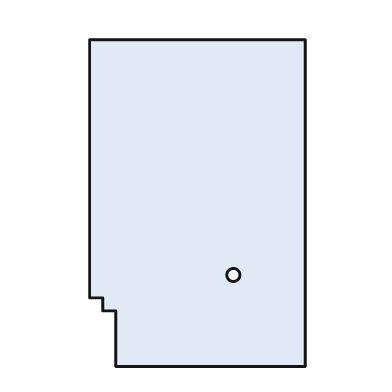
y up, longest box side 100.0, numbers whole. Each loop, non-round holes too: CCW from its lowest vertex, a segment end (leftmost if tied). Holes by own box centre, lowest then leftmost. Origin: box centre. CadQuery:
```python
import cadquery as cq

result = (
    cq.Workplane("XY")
    .moveTo(-25.0, -50.0)
    .lineTo(33.0, -50.0)
    .lineTo(33.0, 50.0)
    .lineTo(-33.0, 50.0)
    .lineTo(-33.0, -29.0)
    .lineTo(-29.0, -29.0)
    .lineTo(-29.0, -33.0)
    .lineTo(-25.0, -33.0)
    .close()
    .moveTo(11.0, -22.0)
    .circle(2.0)
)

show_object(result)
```